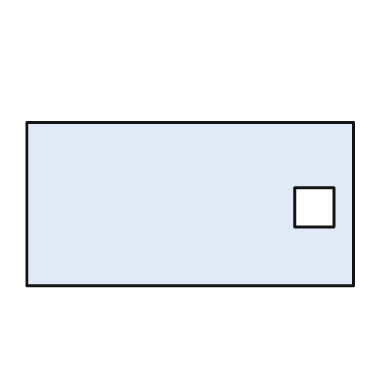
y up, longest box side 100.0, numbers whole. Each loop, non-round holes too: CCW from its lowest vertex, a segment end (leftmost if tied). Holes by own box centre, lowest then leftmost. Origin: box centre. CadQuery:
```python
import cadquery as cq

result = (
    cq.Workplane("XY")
    .moveTo(-50.0, -25.0)
    .lineTo(50.0, -25.0)
    .lineTo(50.0, 25.0)
    .lineTo(-50.0, 25.0)
    .close()
    .moveTo(32.0, -7.0)
    .lineTo(44.0, -7.0)
    .lineTo(44.0, 5.0)
    .lineTo(32.0, 5.0)
    .close()
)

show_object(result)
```